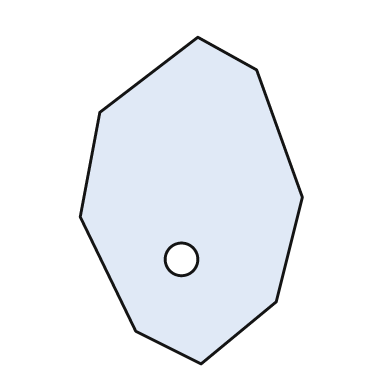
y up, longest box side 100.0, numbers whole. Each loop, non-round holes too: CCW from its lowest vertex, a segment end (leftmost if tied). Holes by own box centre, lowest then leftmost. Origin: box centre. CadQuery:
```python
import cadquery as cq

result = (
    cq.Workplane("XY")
    .moveTo(3.0, -50.0)
    .lineTo(26.0, -31.0)
    .lineTo(34.0, 1.0)
    .lineTo(20.0, 40.0)
    .lineTo(2.0, 50.0)
    .lineTo(-28.0, 27.0)
    .lineTo(-34.0, -5.0)
    .lineTo(-17.0, -40.0)
    .close()
    .moveTo(-3.0, -18.0)
    .circle(5.0)
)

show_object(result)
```